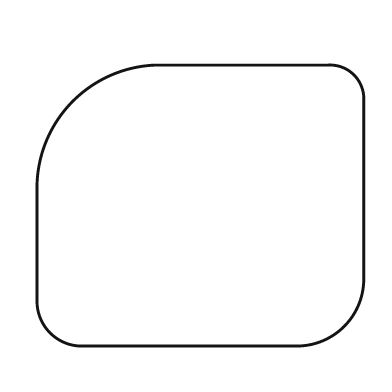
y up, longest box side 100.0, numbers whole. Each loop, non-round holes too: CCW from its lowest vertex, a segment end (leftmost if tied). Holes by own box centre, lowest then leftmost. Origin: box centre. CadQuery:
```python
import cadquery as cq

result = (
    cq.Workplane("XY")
    .moveTo(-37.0, -43.0)
    .lineTo(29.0, -43.0)
    .threePointArc((44.0, -37.0), (50.0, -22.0))
    .lineTo(50.0, 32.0)
    .threePointArc((47.0, 40.0), (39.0, 43.0))
    .lineTo(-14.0, 43.0)
    .threePointArc((-39.0, 32.0), (-50.0, 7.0))
    .lineTo(-50.0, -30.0)
    .threePointArc((-46.0, -39.0), (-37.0, -43.0))
    .close()
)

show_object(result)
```